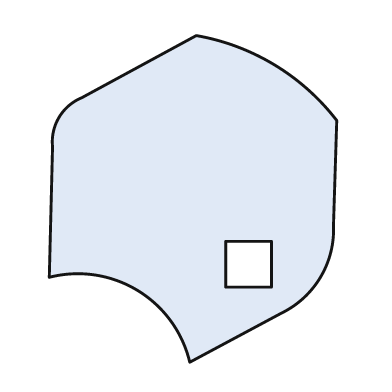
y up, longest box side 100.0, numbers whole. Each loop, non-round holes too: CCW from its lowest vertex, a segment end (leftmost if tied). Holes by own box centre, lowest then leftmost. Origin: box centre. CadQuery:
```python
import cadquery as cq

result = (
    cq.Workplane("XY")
    .moveTo(-1.0, -50.0)
    .lineTo(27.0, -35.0)
    .threePointArc((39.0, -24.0), (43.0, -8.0))
    .lineTo(44.0, 24.0)
    .threePointArc((25.0, 41.0), (1.0, 50.0))
    .lineTo(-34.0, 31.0)
    .threePointArc((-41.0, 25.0), (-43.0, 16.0))
    .lineTo(-44.0, -24.0)
    .threePointArc((-17.0, -28.0), (-1.0, -50.0))
    .close()
    .moveTo(10.0, -27.0)
    .lineTo(24.0, -27.0)
    .lineTo(24.0, -13.0)
    .lineTo(10.0, -13.0)
    .close()
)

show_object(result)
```